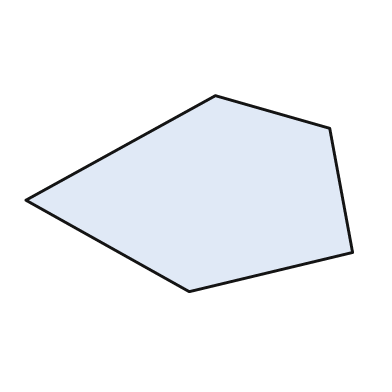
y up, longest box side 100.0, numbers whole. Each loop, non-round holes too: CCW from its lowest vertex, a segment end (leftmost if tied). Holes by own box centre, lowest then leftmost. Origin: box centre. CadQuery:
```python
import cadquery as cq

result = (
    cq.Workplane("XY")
    .moveTo(0.0, -30.0)
    .lineTo(50.0, -18.0)
    .lineTo(43.0, 20.0)
    .lineTo(8.0, 30.0)
    .lineTo(-50.0, -2.0)
    .close()
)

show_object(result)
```